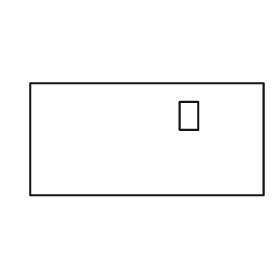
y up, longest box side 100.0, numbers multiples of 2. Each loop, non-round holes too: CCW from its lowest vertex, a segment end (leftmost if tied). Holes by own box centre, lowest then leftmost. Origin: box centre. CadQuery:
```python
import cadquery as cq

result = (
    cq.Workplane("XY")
    .moveTo(-50.0, -24.0)
    .lineTo(50.0, -24.0)
    .lineTo(50.0, 24.0)
    .lineTo(-50.0, 24.0)
    .close()
    .moveTo(14.0, 4.0)
    .lineTo(22.0, 4.0)
    .lineTo(22.0, 16.0)
    .lineTo(14.0, 16.0)
    .close()
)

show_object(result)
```